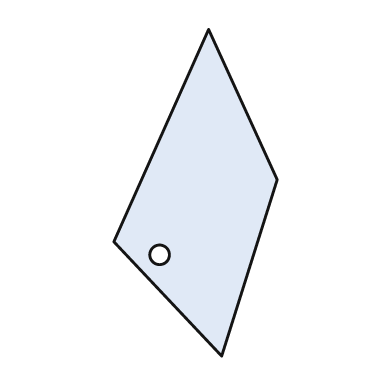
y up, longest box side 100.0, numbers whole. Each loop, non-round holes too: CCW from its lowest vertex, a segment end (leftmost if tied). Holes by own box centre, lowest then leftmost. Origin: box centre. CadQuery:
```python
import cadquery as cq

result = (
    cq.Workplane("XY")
    .moveTo(8.0, -50.0)
    .lineTo(25.0, 4.0)
    .lineTo(4.0, 50.0)
    .lineTo(-25.0, -15.0)
    .close()
    .moveTo(-11.0, -19.0)
    .circle(3.0)
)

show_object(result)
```